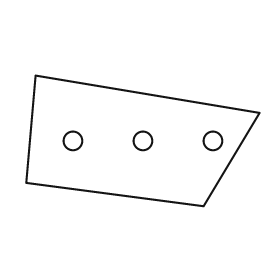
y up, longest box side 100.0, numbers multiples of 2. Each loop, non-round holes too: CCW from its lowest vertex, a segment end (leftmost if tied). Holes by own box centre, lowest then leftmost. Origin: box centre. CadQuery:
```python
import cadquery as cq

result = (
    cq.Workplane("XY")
    .moveTo(26.0, -28.0)
    .lineTo(50.0, 12.0)
    .lineTo(-46.0, 28.0)
    .lineTo(-50.0, -18.0)
    .close()
    .moveTo(-30.0, 0.0)
    .circle(4.0)
    .moveTo(0.0, 0.0)
    .circle(4.0)
    .moveTo(30.0, 0.0)
    .circle(4.0)
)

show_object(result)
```